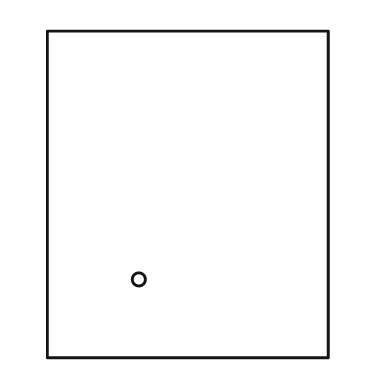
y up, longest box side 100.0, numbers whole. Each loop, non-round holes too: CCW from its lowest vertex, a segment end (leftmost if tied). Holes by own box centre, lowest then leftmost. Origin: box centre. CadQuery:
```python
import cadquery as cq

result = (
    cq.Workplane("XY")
    .moveTo(-43.0, -50.0)
    .lineTo(43.0, -50.0)
    .lineTo(43.0, 50.0)
    .lineTo(-43.0, 50.0)
    .close()
    .moveTo(-15.0, -26.0)
    .circle(2.0)
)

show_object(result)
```